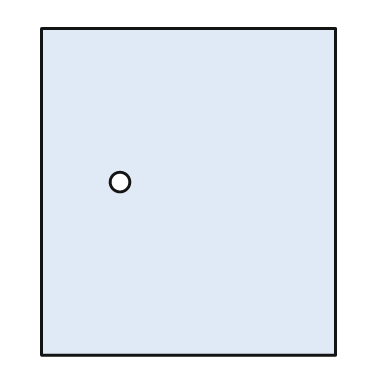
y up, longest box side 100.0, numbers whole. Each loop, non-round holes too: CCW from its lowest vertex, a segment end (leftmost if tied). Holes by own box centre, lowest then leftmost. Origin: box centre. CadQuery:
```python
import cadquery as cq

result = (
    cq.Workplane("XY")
    .moveTo(-45.0, -50.0)
    .lineTo(45.0, -50.0)
    .lineTo(45.0, 50.0)
    .lineTo(-45.0, 50.0)
    .close()
    .moveTo(-21.0, 3.0)
    .circle(3.0)
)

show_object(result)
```